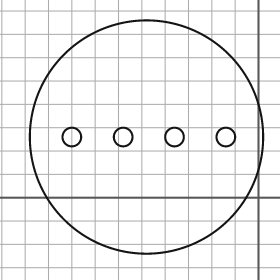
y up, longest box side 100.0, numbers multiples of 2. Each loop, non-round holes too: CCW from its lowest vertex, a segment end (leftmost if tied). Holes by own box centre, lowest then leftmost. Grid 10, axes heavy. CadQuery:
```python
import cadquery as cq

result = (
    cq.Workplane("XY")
    .moveTo(-48.0, 26.0)
    .circle(50.0)
    .moveTo(-80.0, 26.0)
    .circle(4.0)
    .moveTo(-58.0, 26.0)
    .circle(4.0)
    .moveTo(-36.0, 26.0)
    .circle(4.0)
    .moveTo(-14.0, 26.0)
    .circle(4.0)
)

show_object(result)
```